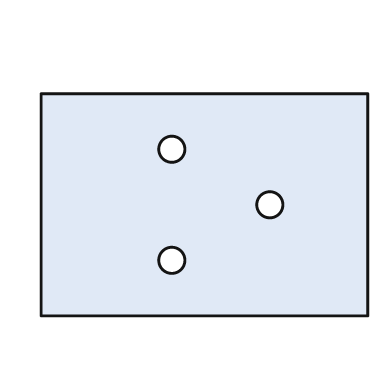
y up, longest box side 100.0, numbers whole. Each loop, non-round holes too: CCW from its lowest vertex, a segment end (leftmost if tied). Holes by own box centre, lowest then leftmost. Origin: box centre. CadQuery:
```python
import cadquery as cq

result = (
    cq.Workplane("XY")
    .moveTo(-50.0, -34.0)
    .lineTo(50.0, -34.0)
    .lineTo(50.0, 34.0)
    .lineTo(-50.0, 34.0)
    .close()
    .moveTo(-10.0, -17.0)
    .circle(4.0)
    .moveTo(20.0, 0.0)
    .circle(4.0)
    .moveTo(-10.0, 17.0)
    .circle(4.0)
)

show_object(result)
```